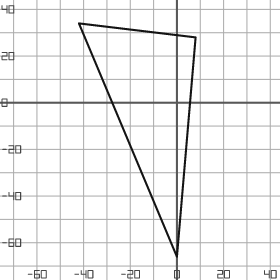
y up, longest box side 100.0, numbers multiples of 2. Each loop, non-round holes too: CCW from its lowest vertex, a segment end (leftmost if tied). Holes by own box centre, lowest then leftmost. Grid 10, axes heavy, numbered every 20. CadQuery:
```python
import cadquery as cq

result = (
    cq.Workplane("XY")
    .moveTo(0.0, -66.0)
    .lineTo(8.0, 28.0)
    .lineTo(-42.0, 34.0)
    .close()
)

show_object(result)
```